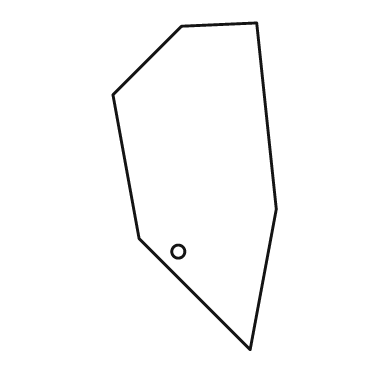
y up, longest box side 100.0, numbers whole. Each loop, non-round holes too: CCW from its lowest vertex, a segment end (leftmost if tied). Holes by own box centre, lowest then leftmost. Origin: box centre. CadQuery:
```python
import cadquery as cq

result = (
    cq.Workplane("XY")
    .moveTo(17.0, -50.0)
    .lineTo(25.0, -7.0)
    .lineTo(19.0, 50.0)
    .lineTo(-4.0, 49.0)
    .lineTo(-25.0, 28.0)
    .lineTo(-17.0, -16.0)
    .close()
    .moveTo(-5.0, -20.0)
    .circle(2.0)
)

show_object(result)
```